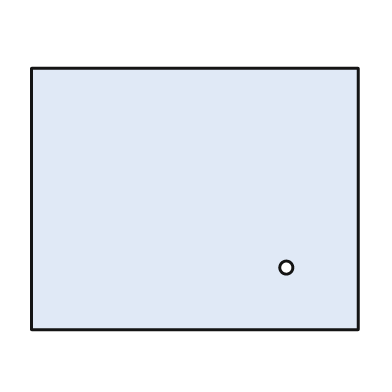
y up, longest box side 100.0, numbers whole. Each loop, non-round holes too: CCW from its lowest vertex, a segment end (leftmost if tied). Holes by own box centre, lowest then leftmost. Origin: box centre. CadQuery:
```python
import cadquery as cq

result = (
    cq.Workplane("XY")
    .moveTo(-50.0, -40.0)
    .lineTo(50.0, -40.0)
    .lineTo(50.0, 40.0)
    .lineTo(-50.0, 40.0)
    .close()
    .moveTo(28.0, -21.0)
    .circle(2.0)
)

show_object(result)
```